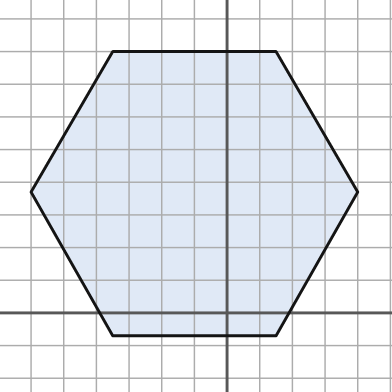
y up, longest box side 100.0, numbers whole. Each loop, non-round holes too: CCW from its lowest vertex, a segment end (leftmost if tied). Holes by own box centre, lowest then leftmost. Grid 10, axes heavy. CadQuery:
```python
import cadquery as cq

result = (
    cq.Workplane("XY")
    .moveTo(-35.0, -7.0)
    .lineTo(15.0, -7.0)
    .lineTo(40.0, 37.0)
    .lineTo(15.0, 80.0)
    .lineTo(-35.0, 80.0)
    .lineTo(-60.0, 37.0)
    .close()
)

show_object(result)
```